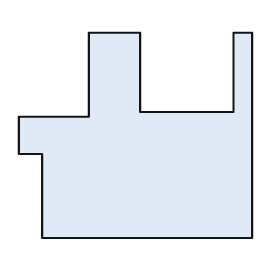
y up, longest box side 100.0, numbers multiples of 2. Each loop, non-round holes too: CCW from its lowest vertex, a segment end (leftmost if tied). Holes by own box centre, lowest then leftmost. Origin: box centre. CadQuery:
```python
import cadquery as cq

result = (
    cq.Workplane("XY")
    .moveTo(-40.0, -44.0)
    .lineTo(50.0, -44.0)
    .lineTo(50.0, 44.0)
    .lineTo(42.0, 44.0)
    .lineTo(42.0, 10.0)
    .lineTo(2.0, 10.0)
    .lineTo(2.0, 44.0)
    .lineTo(-20.0, 44.0)
    .lineTo(-20.0, 8.0)
    .lineTo(-50.0, 8.0)
    .lineTo(-50.0, -8.0)
    .lineTo(-40.0, -8.0)
    .close()
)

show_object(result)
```